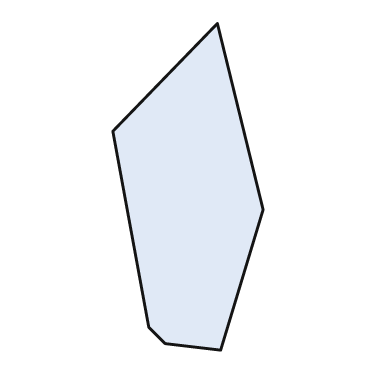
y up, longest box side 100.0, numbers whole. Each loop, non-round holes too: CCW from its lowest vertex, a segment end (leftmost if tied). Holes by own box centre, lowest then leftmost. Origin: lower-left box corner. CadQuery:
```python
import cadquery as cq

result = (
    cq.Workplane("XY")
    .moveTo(33.0, 0.0)
    .lineTo(46.0, 43.0)
    .lineTo(32.0, 100.0)
    .lineTo(0.0, 67.0)
    .lineTo(11.0, 7.0)
    .lineTo(16.0, 2.0)
    .close()
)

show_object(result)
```